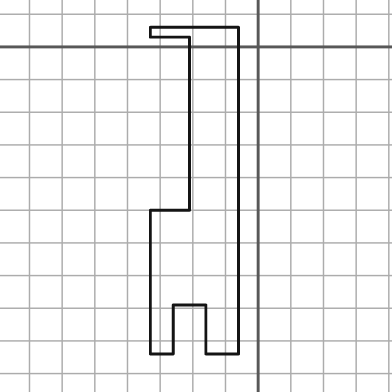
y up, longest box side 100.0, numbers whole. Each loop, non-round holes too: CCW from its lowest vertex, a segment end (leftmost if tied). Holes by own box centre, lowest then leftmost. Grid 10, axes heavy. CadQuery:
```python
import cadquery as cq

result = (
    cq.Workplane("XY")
    .moveTo(-33.0, -94.0)
    .lineTo(-26.0, -94.0)
    .lineTo(-26.0, -79.0)
    .lineTo(-16.0, -79.0)
    .lineTo(-16.0, -94.0)
    .lineTo(-6.0, -94.0)
    .lineTo(-6.0, 6.0)
    .lineTo(-33.0, 6.0)
    .lineTo(-33.0, 3.0)
    .lineTo(-21.0, 3.0)
    .lineTo(-21.0, -50.0)
    .lineTo(-33.0, -50.0)
    .close()
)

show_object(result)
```